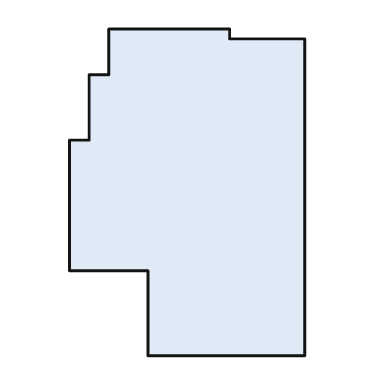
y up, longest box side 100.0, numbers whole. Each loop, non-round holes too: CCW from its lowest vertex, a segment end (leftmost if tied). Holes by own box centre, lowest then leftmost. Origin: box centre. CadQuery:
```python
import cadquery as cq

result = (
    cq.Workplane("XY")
    .moveTo(-12.0, -50.0)
    .lineTo(36.0, -50.0)
    .lineTo(36.0, 47.0)
    .lineTo(13.0, 47.0)
    .lineTo(13.0, 50.0)
    .lineTo(-24.0, 50.0)
    .lineTo(-24.0, 36.0)
    .lineTo(-30.0, 36.0)
    .lineTo(-30.0, 16.0)
    .lineTo(-36.0, 16.0)
    .lineTo(-36.0, -24.0)
    .lineTo(-12.0, -24.0)
    .close()
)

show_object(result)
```